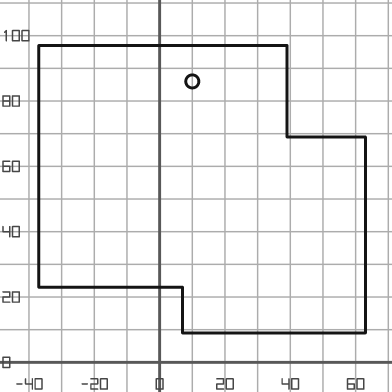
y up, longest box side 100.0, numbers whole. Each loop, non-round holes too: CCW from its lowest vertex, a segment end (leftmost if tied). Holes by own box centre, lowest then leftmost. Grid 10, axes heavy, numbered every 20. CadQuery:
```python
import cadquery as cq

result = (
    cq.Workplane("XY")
    .moveTo(7.0, 9.0)
    .lineTo(63.0, 9.0)
    .lineTo(63.0, 69.0)
    .lineTo(39.0, 69.0)
    .lineTo(39.0, 97.0)
    .lineTo(-37.0, 97.0)
    .lineTo(-37.0, 23.0)
    .lineTo(7.0, 23.0)
    .close()
    .moveTo(10.0, 86.0)
    .circle(2.0)
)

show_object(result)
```